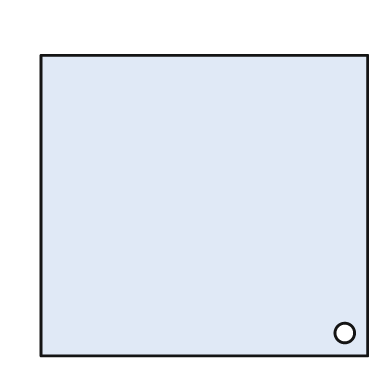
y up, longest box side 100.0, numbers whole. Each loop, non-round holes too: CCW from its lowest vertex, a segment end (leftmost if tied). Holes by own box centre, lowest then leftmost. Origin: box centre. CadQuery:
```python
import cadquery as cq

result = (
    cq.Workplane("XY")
    .moveTo(-50.0, -46.0)
    .lineTo(50.0, -46.0)
    .lineTo(50.0, 46.0)
    .lineTo(-50.0, 46.0)
    .close()
    .moveTo(43.0, -39.0)
    .circle(3.0)
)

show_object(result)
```